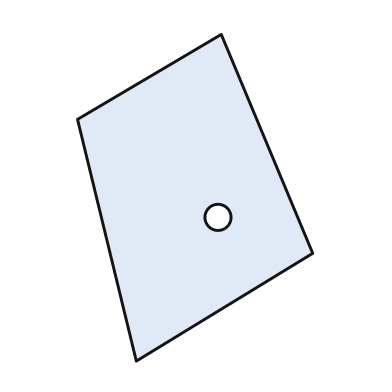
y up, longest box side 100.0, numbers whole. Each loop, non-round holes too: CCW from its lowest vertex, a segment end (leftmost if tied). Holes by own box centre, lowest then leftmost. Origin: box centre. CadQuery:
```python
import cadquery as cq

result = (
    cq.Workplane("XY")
    .moveTo(-18.0, -50.0)
    .lineTo(36.0, -17.0)
    .lineTo(8.0, 50.0)
    .lineTo(-36.0, 24.0)
    .close()
    .moveTo(7.0, -6.0)
    .circle(4.0)
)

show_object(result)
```